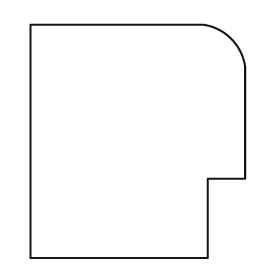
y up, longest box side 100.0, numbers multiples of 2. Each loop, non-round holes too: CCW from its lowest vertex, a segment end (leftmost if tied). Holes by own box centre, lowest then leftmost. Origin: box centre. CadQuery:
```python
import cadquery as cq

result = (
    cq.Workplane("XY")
    .moveTo(-46.0, -50.0)
    .lineTo(30.0, -50.0)
    .lineTo(30.0, -16.0)
    .lineTo(46.0, -16.0)
    .lineTo(46.0, 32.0)
    .threePointArc((40.0, 44.0), (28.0, 50.0))
    .lineTo(-46.0, 50.0)
    .close()
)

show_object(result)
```